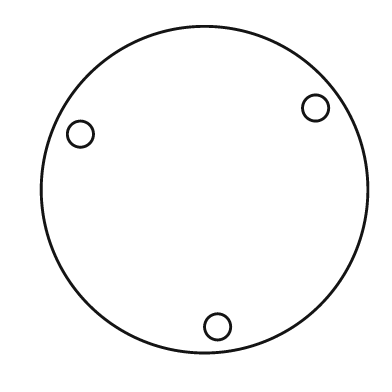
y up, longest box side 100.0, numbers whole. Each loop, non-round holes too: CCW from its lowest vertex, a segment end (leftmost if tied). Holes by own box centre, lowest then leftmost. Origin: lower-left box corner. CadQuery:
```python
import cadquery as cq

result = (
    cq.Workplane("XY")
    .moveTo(50.0, 50.0)
    .circle(50.0)
    .moveTo(54.0, 8.0)
    .circle(4.0)
    .moveTo(12.0, 67.0)
    .circle(4.0)
    .moveTo(84.0, 75.0)
    .circle(4.0)
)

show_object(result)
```